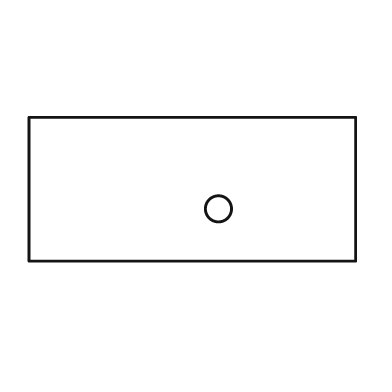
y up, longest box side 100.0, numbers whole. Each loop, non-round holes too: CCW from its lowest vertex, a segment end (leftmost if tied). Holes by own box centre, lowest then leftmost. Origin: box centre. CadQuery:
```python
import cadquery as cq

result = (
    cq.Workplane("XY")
    .moveTo(-50.0, -22.0)
    .lineTo(50.0, -22.0)
    .lineTo(50.0, 22.0)
    .lineTo(-50.0, 22.0)
    .close()
    .moveTo(8.0, -6.0)
    .circle(4.0)
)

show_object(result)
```